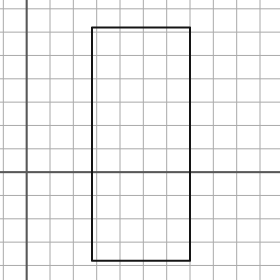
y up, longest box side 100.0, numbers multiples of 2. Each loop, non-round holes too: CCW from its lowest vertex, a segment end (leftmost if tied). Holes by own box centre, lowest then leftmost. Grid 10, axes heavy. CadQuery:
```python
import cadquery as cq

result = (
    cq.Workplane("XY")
    .moveTo(28.0, -38.0)
    .lineTo(70.0, -38.0)
    .lineTo(70.0, 62.0)
    .lineTo(28.0, 62.0)
    .close()
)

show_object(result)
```